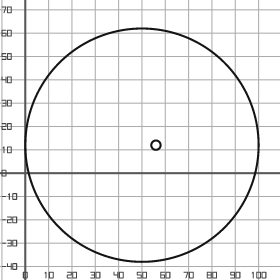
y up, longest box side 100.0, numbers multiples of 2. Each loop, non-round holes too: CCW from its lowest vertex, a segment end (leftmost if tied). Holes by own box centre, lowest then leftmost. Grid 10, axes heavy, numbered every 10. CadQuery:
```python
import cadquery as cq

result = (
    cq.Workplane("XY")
    .moveTo(50.0, 12.0)
    .circle(50.0)
    .moveTo(56.0, 12.0)
    .circle(2.0)
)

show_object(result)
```